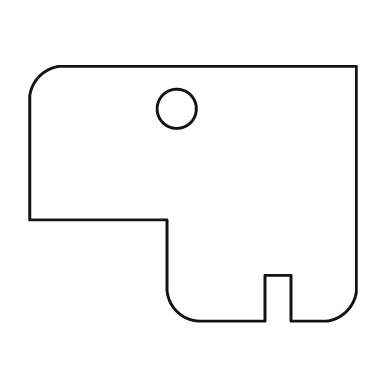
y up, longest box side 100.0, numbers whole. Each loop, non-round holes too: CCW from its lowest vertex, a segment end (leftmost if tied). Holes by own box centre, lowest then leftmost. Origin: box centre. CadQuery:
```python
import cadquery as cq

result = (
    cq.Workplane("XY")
    .moveTo(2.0, -39.0)
    .lineTo(22.0, -39.0)
    .lineTo(22.0, -25.0)
    .lineTo(30.0, -25.0)
    .lineTo(30.0, -39.0)
    .lineTo(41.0, -39.0)
    .threePointArc((47.0, -36.0), (50.0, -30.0))
    .lineTo(50.0, 39.0)
    .lineTo(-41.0, 39.0)
    .threePointArc((-47.0, 36.0), (-50.0, 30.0))
    .lineTo(-50.0, -8.0)
    .lineTo(-8.0, -8.0)
    .lineTo(-8.0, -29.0)
    .threePointArc((-5.0, -36.0), (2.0, -39.0))
    .close()
    .moveTo(-5.0, 26.0)
    .circle(6.0)
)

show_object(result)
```